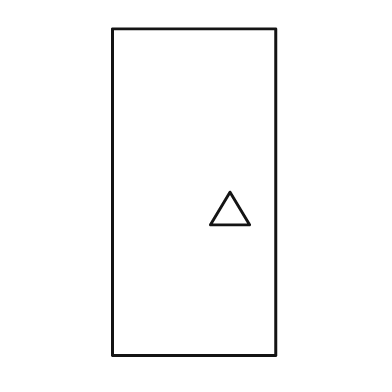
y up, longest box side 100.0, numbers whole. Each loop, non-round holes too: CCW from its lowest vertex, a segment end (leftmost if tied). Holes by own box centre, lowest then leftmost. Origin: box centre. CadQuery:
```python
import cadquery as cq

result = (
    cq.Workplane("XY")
    .moveTo(-25.0, -50.0)
    .lineTo(25.0, -50.0)
    .lineTo(25.0, 50.0)
    .lineTo(-25.0, 50.0)
    .close()
    .moveTo(5.0, -10.0)
    .lineTo(17.0, -10.0)
    .lineTo(11.0, 0.0)
    .close()
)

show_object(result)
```